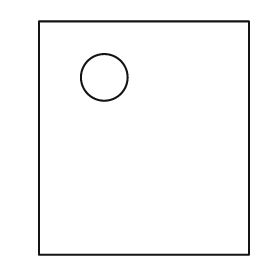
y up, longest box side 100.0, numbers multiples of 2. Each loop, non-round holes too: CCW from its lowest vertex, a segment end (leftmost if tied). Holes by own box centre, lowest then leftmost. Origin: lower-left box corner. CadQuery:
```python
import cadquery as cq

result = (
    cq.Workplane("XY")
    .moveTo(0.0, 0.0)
    .lineTo(90.0, 0.0)
    .lineTo(90.0, 100.0)
    .lineTo(0.0, 100.0)
    .close()
    .moveTo(28.0, 76.0)
    .circle(10.0)
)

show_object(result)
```